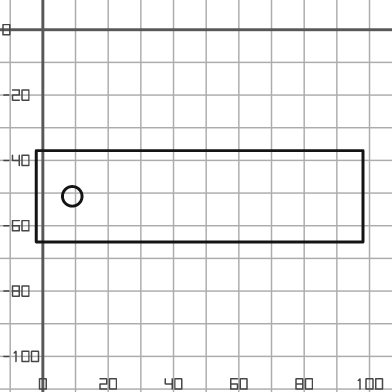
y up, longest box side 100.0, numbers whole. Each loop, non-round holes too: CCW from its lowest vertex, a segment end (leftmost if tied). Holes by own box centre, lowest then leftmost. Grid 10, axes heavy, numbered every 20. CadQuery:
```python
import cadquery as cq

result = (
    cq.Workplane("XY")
    .moveTo(-2.0, -65.0)
    .lineTo(98.0, -65.0)
    .lineTo(98.0, -37.0)
    .lineTo(-2.0, -37.0)
    .close()
    .moveTo(9.0, -51.0)
    .circle(3.0)
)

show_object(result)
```